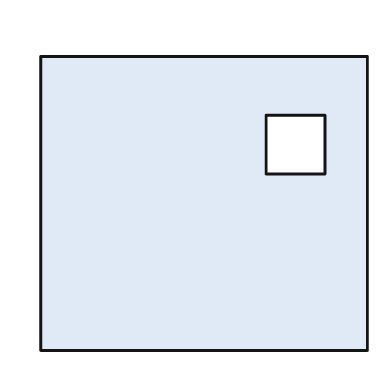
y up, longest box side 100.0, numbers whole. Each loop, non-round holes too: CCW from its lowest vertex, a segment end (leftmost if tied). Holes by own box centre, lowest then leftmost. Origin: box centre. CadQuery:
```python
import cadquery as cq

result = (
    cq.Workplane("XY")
    .moveTo(-50.0, -45.0)
    .lineTo(50.0, -45.0)
    .lineTo(50.0, 45.0)
    .lineTo(-50.0, 45.0)
    .close()
    .moveTo(19.0, 9.0)
    .lineTo(37.0, 9.0)
    .lineTo(37.0, 27.0)
    .lineTo(19.0, 27.0)
    .close()
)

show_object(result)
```